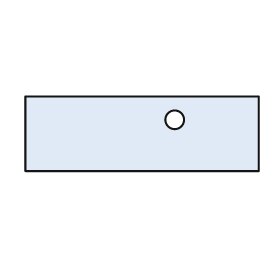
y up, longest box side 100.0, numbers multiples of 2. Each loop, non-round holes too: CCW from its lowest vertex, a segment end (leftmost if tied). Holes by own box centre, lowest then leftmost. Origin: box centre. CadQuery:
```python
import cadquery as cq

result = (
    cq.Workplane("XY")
    .moveTo(-50.0, -16.0)
    .lineTo(50.0, -16.0)
    .lineTo(50.0, 16.0)
    .lineTo(-50.0, 16.0)
    .close()
    .moveTo(14.0, 6.0)
    .circle(4.0)
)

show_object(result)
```